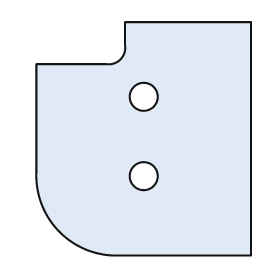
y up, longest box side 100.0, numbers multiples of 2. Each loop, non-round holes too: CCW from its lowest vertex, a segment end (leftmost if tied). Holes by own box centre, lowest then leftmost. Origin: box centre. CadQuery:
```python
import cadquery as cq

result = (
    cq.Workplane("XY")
    .moveTo(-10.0, -50.0)
    .lineTo(46.0, -50.0)
    .lineTo(46.0, 50.0)
    .lineTo(-8.0, 50.0)
    .lineTo(-8.0, 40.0)
    .threePointArc((-10.0, 34.0), (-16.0, 32.0))
    .lineTo(-46.0, 32.0)
    .lineTo(-46.0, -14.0)
    .threePointArc((-36.0, -40.0), (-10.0, -50.0))
    .close()
    .moveTo(0.0, -16.0)
    .circle(6.0)
    .moveTo(0.0, 18.0)
    .circle(6.0)
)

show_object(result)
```